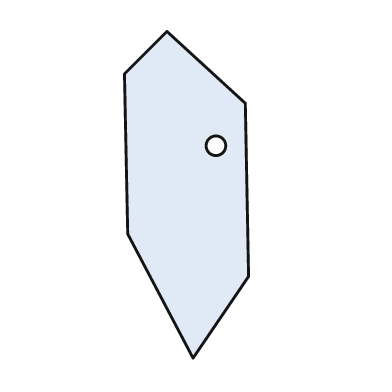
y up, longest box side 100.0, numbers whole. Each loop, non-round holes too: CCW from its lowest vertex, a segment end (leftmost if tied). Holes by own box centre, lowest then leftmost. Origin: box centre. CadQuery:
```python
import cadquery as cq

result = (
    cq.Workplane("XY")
    .moveTo(2.0, -50.0)
    .lineTo(19.0, -25.0)
    .lineTo(18.0, 28.0)
    .lineTo(-6.0, 50.0)
    .lineTo(-19.0, 37.0)
    .lineTo(-18.0, -12.0)
    .close()
    .moveTo(9.0, 15.0)
    .circle(3.0)
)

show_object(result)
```